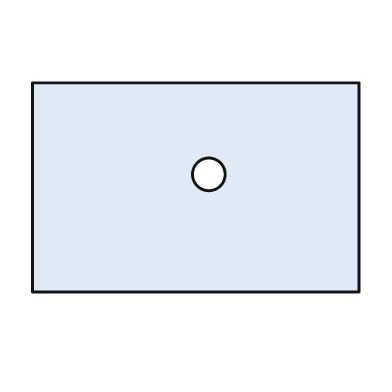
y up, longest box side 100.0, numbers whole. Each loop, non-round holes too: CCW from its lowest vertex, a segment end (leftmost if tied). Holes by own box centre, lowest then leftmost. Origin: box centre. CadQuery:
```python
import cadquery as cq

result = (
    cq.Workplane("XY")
    .moveTo(-50.0, -32.0)
    .lineTo(50.0, -32.0)
    .lineTo(50.0, 32.0)
    .lineTo(-50.0, 32.0)
    .close()
    .moveTo(4.0, 4.0)
    .circle(5.0)
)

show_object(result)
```